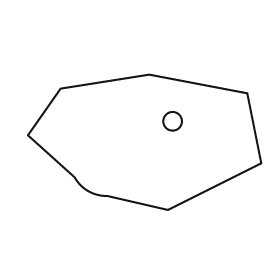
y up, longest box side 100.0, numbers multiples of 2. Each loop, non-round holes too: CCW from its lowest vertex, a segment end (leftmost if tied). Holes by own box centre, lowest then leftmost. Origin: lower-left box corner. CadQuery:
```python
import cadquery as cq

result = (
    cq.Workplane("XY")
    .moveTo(60.0, 0.0)
    .lineTo(100.0, 20.0)
    .lineTo(94.0, 50.0)
    .lineTo(52.0, 58.0)
    .lineTo(14.0, 52.0)
    .lineTo(0.0, 32.0)
    .lineTo(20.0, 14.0)
    .threePointArc((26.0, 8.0), (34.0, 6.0))
    .close()
    .moveTo(62.0, 38.0)
    .circle(4.0)
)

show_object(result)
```